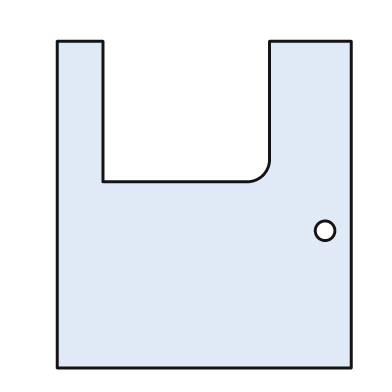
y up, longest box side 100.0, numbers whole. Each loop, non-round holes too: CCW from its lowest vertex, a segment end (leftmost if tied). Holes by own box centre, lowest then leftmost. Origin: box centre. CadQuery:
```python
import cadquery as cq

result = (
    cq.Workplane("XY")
    .moveTo(-45.0, -50.0)
    .lineTo(45.0, -50.0)
    .lineTo(45.0, 50.0)
    .lineTo(20.0, 50.0)
    .lineTo(20.0, 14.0)
    .threePointArc((18.0, 9.0), (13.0, 7.0))
    .lineTo(-31.0, 7.0)
    .lineTo(-31.0, 50.0)
    .lineTo(-45.0, 50.0)
    .close()
    .moveTo(37.0, -8.0)
    .circle(3.0)
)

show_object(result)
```